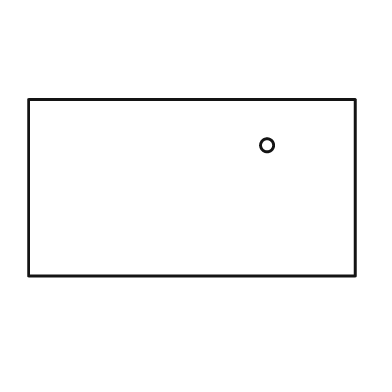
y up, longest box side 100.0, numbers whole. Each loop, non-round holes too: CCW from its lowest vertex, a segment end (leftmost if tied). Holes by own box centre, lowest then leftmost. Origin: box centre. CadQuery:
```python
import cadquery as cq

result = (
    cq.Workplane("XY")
    .moveTo(-50.0, -27.0)
    .lineTo(50.0, -27.0)
    .lineTo(50.0, 27.0)
    .lineTo(-50.0, 27.0)
    .close()
    .moveTo(23.0, 13.0)
    .circle(2.0)
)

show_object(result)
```